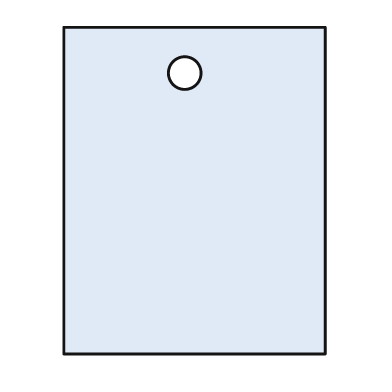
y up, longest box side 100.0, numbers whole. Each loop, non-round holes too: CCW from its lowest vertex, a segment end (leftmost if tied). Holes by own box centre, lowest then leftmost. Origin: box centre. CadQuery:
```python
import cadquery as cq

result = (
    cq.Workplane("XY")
    .moveTo(-40.0, -50.0)
    .lineTo(40.0, -50.0)
    .lineTo(40.0, 50.0)
    .lineTo(-40.0, 50.0)
    .close()
    .moveTo(-3.0, 36.0)
    .circle(5.0)
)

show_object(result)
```